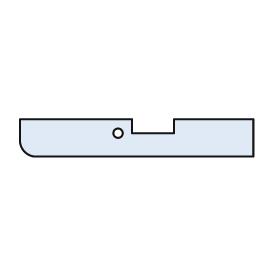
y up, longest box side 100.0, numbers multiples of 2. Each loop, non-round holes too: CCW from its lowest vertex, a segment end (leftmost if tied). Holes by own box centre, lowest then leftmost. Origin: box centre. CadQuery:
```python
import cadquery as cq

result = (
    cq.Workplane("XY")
    .moveTo(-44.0, -8.0)
    .lineTo(50.0, -8.0)
    .lineTo(50.0, 8.0)
    .lineTo(16.0, 8.0)
    .lineTo(16.0, 2.0)
    .lineTo(-2.0, 2.0)
    .lineTo(-2.0, 8.0)
    .lineTo(-50.0, 8.0)
    .lineTo(-50.0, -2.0)
    .threePointArc((-48.0, -6.0), (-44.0, -8.0))
    .close()
    .moveTo(-8.0, 2.0)
    .circle(2.0)
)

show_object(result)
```